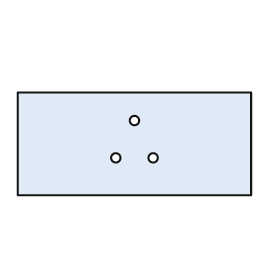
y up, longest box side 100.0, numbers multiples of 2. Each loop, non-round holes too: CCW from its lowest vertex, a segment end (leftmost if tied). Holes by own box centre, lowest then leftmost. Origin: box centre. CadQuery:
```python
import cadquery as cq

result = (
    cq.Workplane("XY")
    .moveTo(-50.0, -22.0)
    .lineTo(50.0, -22.0)
    .lineTo(50.0, 22.0)
    .lineTo(-50.0, 22.0)
    .close()
    .moveTo(-8.0, -6.0)
    .circle(2.0)
    .moveTo(8.0, -6.0)
    .circle(2.0)
    .moveTo(0.0, 10.0)
    .circle(2.0)
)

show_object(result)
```